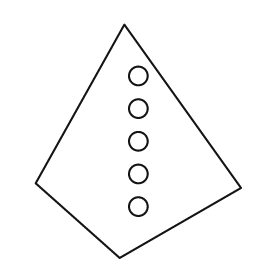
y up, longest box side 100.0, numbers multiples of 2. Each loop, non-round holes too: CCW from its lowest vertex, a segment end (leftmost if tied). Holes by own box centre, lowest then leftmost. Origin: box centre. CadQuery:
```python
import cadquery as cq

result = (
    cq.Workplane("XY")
    .moveTo(-8.0, -50.0)
    .lineTo(44.0, -20.0)
    .lineTo(-6.0, 50.0)
    .lineTo(-44.0, -18.0)
    .close()
    .moveTo(0.0, -28.0)
    .circle(4.0)
    .moveTo(0.0, -14.0)
    .circle(4.0)
    .moveTo(0.0, 0.0)
    .circle(4.0)
    .moveTo(0.0, 14.0)
    .circle(4.0)
    .moveTo(0.0, 28.0)
    .circle(4.0)
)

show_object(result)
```